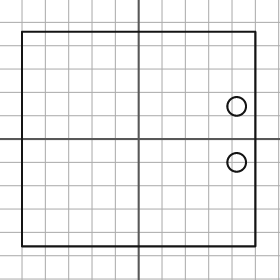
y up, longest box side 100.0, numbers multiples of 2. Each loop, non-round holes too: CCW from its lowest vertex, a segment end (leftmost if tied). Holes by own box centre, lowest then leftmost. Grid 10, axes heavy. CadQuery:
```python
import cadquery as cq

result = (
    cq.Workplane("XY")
    .moveTo(-50.0, -46.0)
    .lineTo(50.0, -46.0)
    .lineTo(50.0, 46.0)
    .lineTo(-50.0, 46.0)
    .close()
    .moveTo(42.0, -10.0)
    .circle(4.0)
    .moveTo(42.0, 14.0)
    .circle(4.0)
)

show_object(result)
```